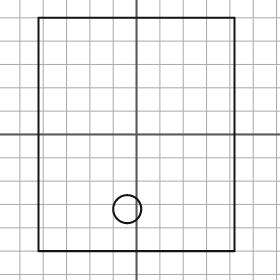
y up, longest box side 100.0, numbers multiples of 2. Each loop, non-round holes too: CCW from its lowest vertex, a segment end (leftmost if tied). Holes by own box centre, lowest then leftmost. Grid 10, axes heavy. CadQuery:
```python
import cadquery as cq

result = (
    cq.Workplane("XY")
    .moveTo(-42.0, -50.0)
    .lineTo(42.0, -50.0)
    .lineTo(42.0, 50.0)
    .lineTo(-42.0, 50.0)
    .close()
    .moveTo(-4.0, -32.0)
    .circle(6.0)
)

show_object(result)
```